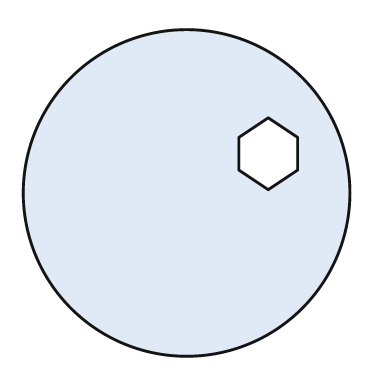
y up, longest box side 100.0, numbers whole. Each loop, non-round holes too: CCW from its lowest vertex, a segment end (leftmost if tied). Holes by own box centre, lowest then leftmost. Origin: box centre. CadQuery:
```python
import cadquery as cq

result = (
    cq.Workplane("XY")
    .moveTo(0.0, 0.0)
    .circle(50.0)
    .moveTo(25.0, 1.0)
    .lineTo(34.0, 7.0)
    .lineTo(34.0, 17.0)
    .lineTo(25.0, 23.0)
    .lineTo(16.0, 17.0)
    .lineTo(16.0, 7.0)
    .close()
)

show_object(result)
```